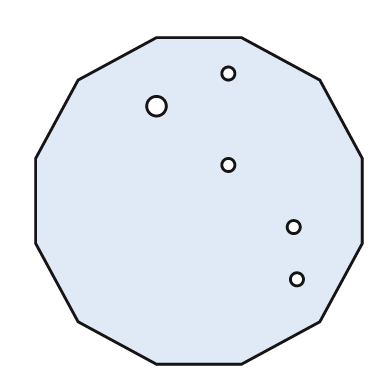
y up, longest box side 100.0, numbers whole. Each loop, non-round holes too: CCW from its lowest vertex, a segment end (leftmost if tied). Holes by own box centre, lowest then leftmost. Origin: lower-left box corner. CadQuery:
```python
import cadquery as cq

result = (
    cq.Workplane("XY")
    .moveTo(37.0, 0.0)
    .lineTo(63.0, 0.0)
    .lineTo(87.0, 13.0)
    .lineTo(100.0, 37.0)
    .lineTo(100.0, 63.0)
    .lineTo(87.0, 87.0)
    .lineTo(63.0, 100.0)
    .lineTo(37.0, 100.0)
    .lineTo(13.0, 87.0)
    .lineTo(0.0, 63.0)
    .lineTo(0.0, 37.0)
    .lineTo(13.0, 13.0)
    .close()
    .moveTo(80.0, 26.0)
    .circle(2.0)
    .moveTo(79.0, 42.0)
    .circle(2.0)
    .moveTo(59.0, 61.0)
    .circle(2.0)
    .moveTo(37.0, 79.0)
    .circle(3.0)
    .moveTo(59.0, 89.0)
    .circle(2.0)
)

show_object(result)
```